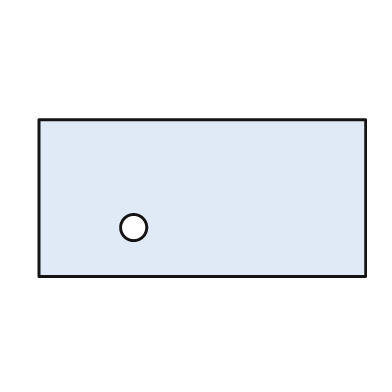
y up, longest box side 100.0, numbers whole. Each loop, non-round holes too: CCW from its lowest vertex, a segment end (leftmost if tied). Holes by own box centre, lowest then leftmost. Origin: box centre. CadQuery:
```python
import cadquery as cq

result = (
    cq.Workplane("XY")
    .moveTo(-50.0, -24.0)
    .lineTo(50.0, -24.0)
    .lineTo(50.0, 24.0)
    .lineTo(-50.0, 24.0)
    .close()
    .moveTo(-21.0, -9.0)
    .circle(4.0)
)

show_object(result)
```